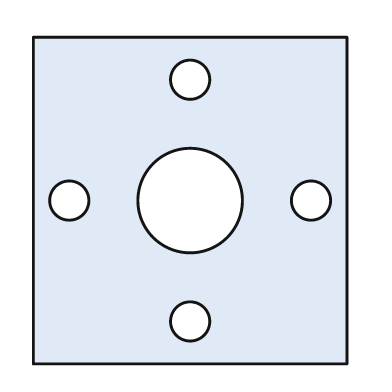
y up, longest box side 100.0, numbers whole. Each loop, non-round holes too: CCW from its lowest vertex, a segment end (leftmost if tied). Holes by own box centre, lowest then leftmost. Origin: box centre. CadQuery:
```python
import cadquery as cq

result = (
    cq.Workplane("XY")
    .moveTo(-48.0, -50.0)
    .lineTo(48.0, -50.0)
    .lineTo(48.0, 50.0)
    .lineTo(-48.0, 50.0)
    .close()
    .moveTo(0.0, -37.0)
    .circle(6.0)
    .moveTo(-37.0, 0.0)
    .circle(6.0)
    .moveTo(0.0, 0.0)
    .circle(16.0)
    .moveTo(37.0, 0.0)
    .circle(6.0)
    .moveTo(0.0, 37.0)
    .circle(6.0)
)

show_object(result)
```